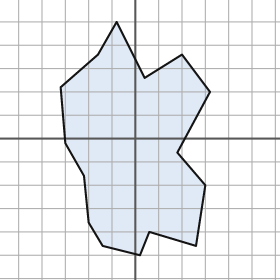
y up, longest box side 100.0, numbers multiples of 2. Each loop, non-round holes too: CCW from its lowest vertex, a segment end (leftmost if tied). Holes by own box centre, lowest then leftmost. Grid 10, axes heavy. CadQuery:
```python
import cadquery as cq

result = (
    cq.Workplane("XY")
    .moveTo(2.0, -50.0)
    .lineTo(6.0, -40.0)
    .lineTo(26.0, -46.0)
    .lineTo(30.0, -20.0)
    .lineTo(18.0, -6.0)
    .lineTo(32.0, 20.0)
    .lineTo(20.0, 36.0)
    .lineTo(4.0, 26.0)
    .lineTo(-8.0, 50.0)
    .lineTo(-16.0, 36.0)
    .lineTo(-32.0, 22.0)
    .lineTo(-30.0, -2.0)
    .lineTo(-22.0, -16.0)
    .lineTo(-20.0, -36.0)
    .lineTo(-14.0, -46.0)
    .close()
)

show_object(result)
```